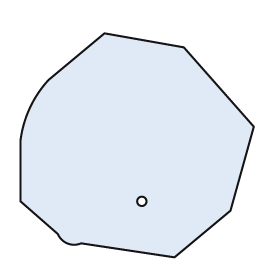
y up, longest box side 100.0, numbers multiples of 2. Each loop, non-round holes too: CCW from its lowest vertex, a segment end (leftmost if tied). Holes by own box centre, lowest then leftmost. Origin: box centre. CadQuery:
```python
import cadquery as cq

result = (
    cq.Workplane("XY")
    .moveTo(16.0, -48.0)
    .lineTo(40.0, -28.0)
    .lineTo(50.0, 8.0)
    .lineTo(20.0, 42.0)
    .lineTo(-14.0, 48.0)
    .lineTo(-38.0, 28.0)
    .threePointArc((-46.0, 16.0), (-50.0, 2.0))
    .lineTo(-50.0, -24.0)
    .lineTo(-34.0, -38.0)
    .threePointArc((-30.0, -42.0), (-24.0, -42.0))
    .close()
    .moveTo(2.0, -24.0)
    .circle(2.0)
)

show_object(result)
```